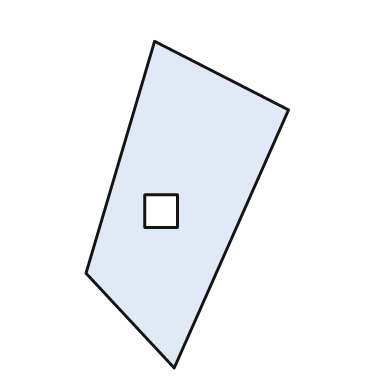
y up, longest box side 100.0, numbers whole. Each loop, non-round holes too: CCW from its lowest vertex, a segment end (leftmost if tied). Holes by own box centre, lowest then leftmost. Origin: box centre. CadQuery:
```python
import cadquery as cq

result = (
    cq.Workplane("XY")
    .moveTo(-4.0, -50.0)
    .lineTo(31.0, 29.0)
    .lineTo(-10.0, 50.0)
    .lineTo(-31.0, -21.0)
    .close()
    .moveTo(-13.0, -7.0)
    .lineTo(-3.0, -7.0)
    .lineTo(-3.0, 3.0)
    .lineTo(-13.0, 3.0)
    .close()
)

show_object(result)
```